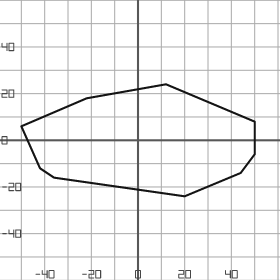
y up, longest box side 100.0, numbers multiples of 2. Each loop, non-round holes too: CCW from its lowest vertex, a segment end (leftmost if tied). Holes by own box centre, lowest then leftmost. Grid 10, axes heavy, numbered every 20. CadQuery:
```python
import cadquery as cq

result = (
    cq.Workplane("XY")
    .moveTo(20.0, -24.0)
    .lineTo(44.0, -14.0)
    .lineTo(50.0, -6.0)
    .lineTo(50.0, 8.0)
    .lineTo(12.0, 24.0)
    .lineTo(-22.0, 18.0)
    .lineTo(-50.0, 6.0)
    .lineTo(-42.0, -12.0)
    .lineTo(-36.0, -16.0)
    .close()
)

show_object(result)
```